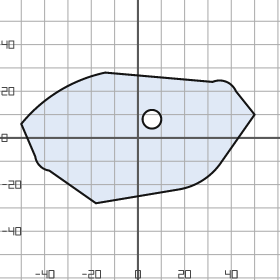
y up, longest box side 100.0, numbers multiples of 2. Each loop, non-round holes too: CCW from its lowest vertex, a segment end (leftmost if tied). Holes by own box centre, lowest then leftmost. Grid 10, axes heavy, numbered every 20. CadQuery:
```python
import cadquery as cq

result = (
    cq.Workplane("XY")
    .moveTo(-18.0, -28.0)
    .lineTo(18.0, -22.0)
    .threePointArc((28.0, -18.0), (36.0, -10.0))
    .lineTo(50.0, 10.0)
    .lineTo(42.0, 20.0)
    .threePointArc((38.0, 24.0), (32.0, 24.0))
    .lineTo(-14.0, 28.0)
    .threePointArc((-34.0, 20.0), (-50.0, 6.0))
    .lineTo(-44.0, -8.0)
    .threePointArc((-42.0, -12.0), (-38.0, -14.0))
    .close()
    .moveTo(6.0, 8.0)
    .circle(4.0)
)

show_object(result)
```